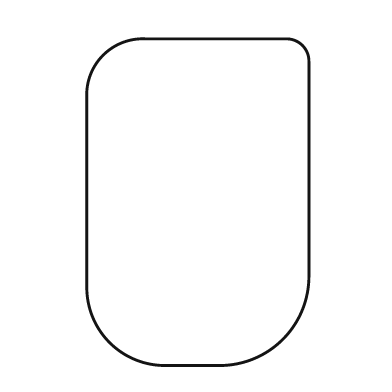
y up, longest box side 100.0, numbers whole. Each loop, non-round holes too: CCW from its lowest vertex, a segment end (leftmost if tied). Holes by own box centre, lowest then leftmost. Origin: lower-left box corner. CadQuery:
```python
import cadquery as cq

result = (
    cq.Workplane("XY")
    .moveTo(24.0, 0.0)
    .lineTo(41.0, 0.0)
    .threePointArc((60.0, 8.0), (68.0, 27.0))
    .lineTo(68.0, 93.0)
    .threePointArc((66.0, 98.0), (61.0, 100.0))
    .lineTo(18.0, 100.0)
    .threePointArc((5.0, 95.0), (0.0, 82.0))
    .lineTo(0.0, 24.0)
    .threePointArc((7.0, 7.0), (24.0, 0.0))
    .close()
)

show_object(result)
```